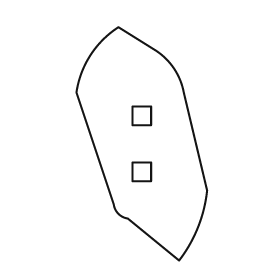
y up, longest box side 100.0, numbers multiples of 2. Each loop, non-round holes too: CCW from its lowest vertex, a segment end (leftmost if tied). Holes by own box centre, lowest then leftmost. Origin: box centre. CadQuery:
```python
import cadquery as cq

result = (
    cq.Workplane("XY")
    .moveTo(16.0, -50.0)
    .threePointArc((24.0, -36.0), (28.0, -20.0))
    .lineTo(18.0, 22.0)
    .threePointArc((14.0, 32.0), (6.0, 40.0))
    .lineTo(-10.0, 50.0)
    .threePointArc((-22.0, 38.0), (-28.0, 22.0))
    .lineTo(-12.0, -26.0)
    .threePointArc((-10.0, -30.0), (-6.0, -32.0))
    .close()
    .moveTo(-4.0, -16.0)
    .lineTo(4.0, -16.0)
    .lineTo(4.0, -8.0)
    .lineTo(-4.0, -8.0)
    .close()
    .moveTo(-4.0, 8.0)
    .lineTo(4.0, 8.0)
    .lineTo(4.0, 16.0)
    .lineTo(-4.0, 16.0)
    .close()
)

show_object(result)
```